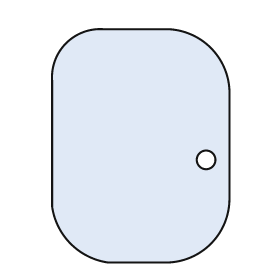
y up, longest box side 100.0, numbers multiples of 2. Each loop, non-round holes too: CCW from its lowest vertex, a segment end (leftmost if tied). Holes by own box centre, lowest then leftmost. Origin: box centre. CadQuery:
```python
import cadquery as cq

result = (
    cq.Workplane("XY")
    .moveTo(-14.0, -50.0)
    .lineTo(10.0, -50.0)
    .threePointArc((30.0, -42.0), (38.0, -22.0))
    .lineTo(38.0, 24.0)
    .threePointArc((30.0, 42.0), (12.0, 50.0))
    .lineTo(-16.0, 50.0)
    .threePointArc((-32.0, 44.0), (-38.0, 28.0))
    .lineTo(-38.0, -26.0)
    .threePointArc((-30.0, -42.0), (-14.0, -50.0))
    .close()
    .moveTo(28.0, -6.0)
    .circle(4.0)
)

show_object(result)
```